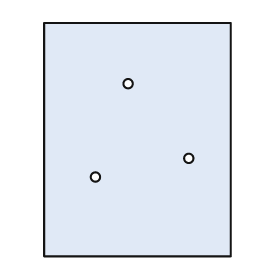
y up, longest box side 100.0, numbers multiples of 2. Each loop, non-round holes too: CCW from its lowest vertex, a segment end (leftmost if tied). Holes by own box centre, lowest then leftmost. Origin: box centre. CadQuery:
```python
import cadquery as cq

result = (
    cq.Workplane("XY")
    .moveTo(-40.0, -50.0)
    .lineTo(40.0, -50.0)
    .lineTo(40.0, 50.0)
    .lineTo(-40.0, 50.0)
    .close()
    .moveTo(-18.0, -16.0)
    .circle(2.0)
    .moveTo(22.0, -8.0)
    .circle(2.0)
    .moveTo(-4.0, 24.0)
    .circle(2.0)
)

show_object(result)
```